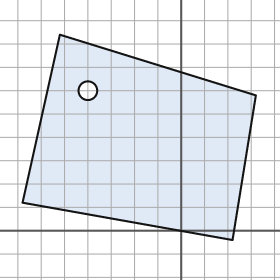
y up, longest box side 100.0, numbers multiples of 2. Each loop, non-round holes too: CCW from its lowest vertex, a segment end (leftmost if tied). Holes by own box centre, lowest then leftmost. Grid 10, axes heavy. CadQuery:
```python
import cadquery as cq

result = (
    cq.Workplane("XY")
    .moveTo(22.0, -4.0)
    .lineTo(32.0, 58.0)
    .lineTo(-52.0, 84.0)
    .lineTo(-68.0, 12.0)
    .close()
    .moveTo(-40.0, 60.0)
    .circle(4.0)
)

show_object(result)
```